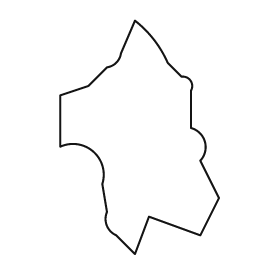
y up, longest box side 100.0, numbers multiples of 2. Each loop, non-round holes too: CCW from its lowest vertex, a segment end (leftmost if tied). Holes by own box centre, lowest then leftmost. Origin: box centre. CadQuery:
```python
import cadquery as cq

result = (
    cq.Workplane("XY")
    .moveTo(-2.0, -50.0)
    .lineTo(4.0, -34.0)
    .lineTo(26.0, -42.0)
    .lineTo(34.0, -26.0)
    .lineTo(26.0, -10.0)
    .threePointArc((28.0, -2.0), (22.0, 4.0))
    .lineTo(22.0, 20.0)
    .threePointArc((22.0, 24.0), (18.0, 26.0))
    .lineTo(12.0, 32.0)
    .threePointArc((6.0, 42.0), (-2.0, 50.0))
    .lineTo(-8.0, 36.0)
    .threePointArc((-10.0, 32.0), (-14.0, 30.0))
    .lineTo(-22.0, 22.0)
    .lineTo(-34.0, 18.0)
    .lineTo(-34.0, -4.0)
    .threePointArc((-20.0, -6.0), (-16.0, -20.0))
    .lineTo(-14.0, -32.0)
    .threePointArc((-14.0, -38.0), (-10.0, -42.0))
    .close()
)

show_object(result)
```